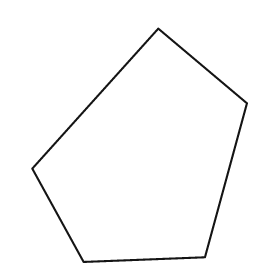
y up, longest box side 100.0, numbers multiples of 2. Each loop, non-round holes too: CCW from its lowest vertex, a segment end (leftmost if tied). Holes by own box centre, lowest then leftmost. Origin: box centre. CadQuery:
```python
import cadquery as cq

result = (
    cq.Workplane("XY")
    .moveTo(-24.0, -50.0)
    .lineTo(28.0, -48.0)
    .lineTo(46.0, 18.0)
    .lineTo(8.0, 50.0)
    .lineTo(-46.0, -10.0)
    .close()
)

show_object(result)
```